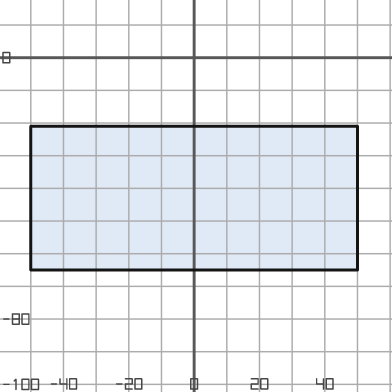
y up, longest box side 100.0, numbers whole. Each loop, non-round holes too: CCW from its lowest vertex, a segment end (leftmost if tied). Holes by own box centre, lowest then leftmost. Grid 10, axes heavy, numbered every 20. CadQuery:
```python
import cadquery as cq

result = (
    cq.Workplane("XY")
    .moveTo(-50.0, -65.0)
    .lineTo(50.0, -65.0)
    .lineTo(50.0, -21.0)
    .lineTo(-50.0, -21.0)
    .close()
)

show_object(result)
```